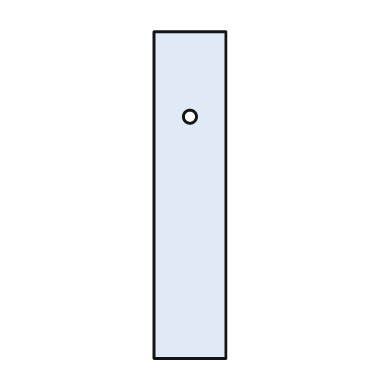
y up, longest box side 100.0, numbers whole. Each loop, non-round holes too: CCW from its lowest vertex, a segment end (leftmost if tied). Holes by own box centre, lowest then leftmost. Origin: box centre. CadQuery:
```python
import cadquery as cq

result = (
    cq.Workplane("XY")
    .moveTo(-11.0, -50.0)
    .lineTo(11.0, -50.0)
    .lineTo(11.0, 50.0)
    .lineTo(-11.0, 50.0)
    .close()
    .moveTo(0.0, 24.0)
    .circle(2.0)
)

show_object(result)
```